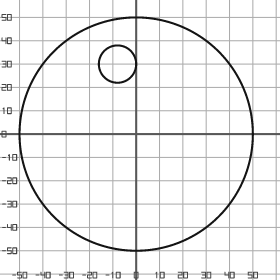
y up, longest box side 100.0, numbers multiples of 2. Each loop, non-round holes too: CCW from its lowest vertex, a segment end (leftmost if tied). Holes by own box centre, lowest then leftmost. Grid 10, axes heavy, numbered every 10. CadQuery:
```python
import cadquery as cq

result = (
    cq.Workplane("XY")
    .moveTo(0.0, 0.0)
    .circle(50.0)
    .moveTo(-8.0, 30.0)
    .circle(8.0)
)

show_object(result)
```